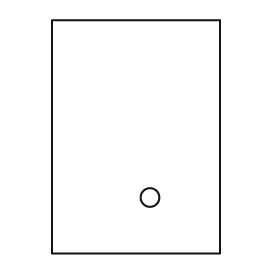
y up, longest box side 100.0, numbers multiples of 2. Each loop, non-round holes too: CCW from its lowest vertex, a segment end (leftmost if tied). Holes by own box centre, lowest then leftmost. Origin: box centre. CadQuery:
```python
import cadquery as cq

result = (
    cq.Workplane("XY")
    .moveTo(-36.0, -50.0)
    .lineTo(36.0, -50.0)
    .lineTo(36.0, 50.0)
    .lineTo(-36.0, 50.0)
    .close()
    .moveTo(6.0, -26.0)
    .circle(4.0)
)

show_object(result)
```